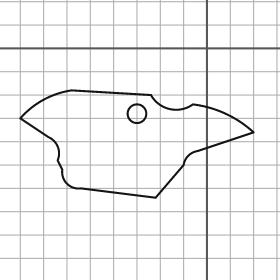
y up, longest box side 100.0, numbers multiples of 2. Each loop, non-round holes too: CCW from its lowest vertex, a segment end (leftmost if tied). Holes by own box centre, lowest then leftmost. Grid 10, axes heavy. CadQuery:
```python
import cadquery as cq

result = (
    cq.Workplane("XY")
    .moveTo(-22.0, -64.0)
    .lineTo(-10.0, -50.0)
    .threePointArc((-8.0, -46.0), (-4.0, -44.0))
    .lineTo(20.0, -36.0)
    .threePointArc((8.0, -28.0), (-6.0, -24.0))
    .threePointArc((-16.0, -26.0), (-24.0, -20.0))
    .lineTo(-58.0, -18.0)
    .threePointArc((-70.0, -22.0), (-80.0, -30.0))
    .lineTo(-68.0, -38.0)
    .threePointArc((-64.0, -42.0), (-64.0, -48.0))
    .lineTo(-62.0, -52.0)
    .threePointArc((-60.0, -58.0), (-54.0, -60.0))
    .close()
    .moveTo(-30.0, -28.0)
    .circle(4.0)
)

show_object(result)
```